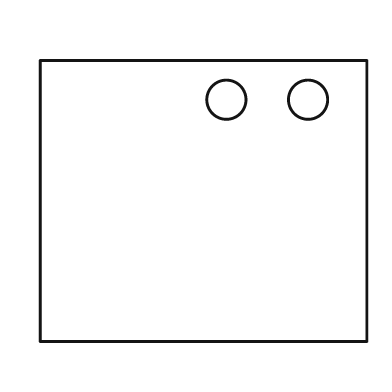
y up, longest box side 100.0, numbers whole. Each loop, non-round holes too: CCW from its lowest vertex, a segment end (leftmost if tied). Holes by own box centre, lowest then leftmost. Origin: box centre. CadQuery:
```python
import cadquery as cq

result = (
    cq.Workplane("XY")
    .moveTo(-50.0, -43.0)
    .lineTo(50.0, -43.0)
    .lineTo(50.0, 43.0)
    .lineTo(-50.0, 43.0)
    .close()
    .moveTo(7.0, 31.0)
    .circle(6.0)
    .moveTo(32.0, 31.0)
    .circle(6.0)
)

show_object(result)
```